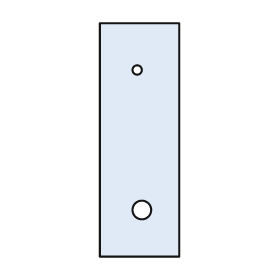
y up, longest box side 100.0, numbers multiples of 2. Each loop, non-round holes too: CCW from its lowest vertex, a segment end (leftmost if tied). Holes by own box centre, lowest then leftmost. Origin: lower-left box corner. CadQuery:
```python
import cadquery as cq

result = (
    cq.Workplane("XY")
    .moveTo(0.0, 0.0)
    .lineTo(34.0, 0.0)
    .lineTo(34.0, 100.0)
    .lineTo(0.0, 100.0)
    .close()
    .moveTo(18.0, 20.0)
    .circle(4.0)
    .moveTo(16.0, 80.0)
    .circle(2.0)
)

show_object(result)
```